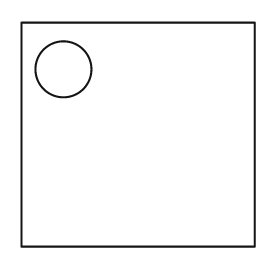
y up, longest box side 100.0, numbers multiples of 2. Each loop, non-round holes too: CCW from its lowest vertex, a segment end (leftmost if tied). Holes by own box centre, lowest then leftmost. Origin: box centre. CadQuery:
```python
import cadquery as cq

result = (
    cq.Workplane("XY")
    .moveTo(-50.0, -48.0)
    .lineTo(50.0, -48.0)
    .lineTo(50.0, 48.0)
    .lineTo(-50.0, 48.0)
    .close()
    .moveTo(-32.0, 28.0)
    .circle(12.0)
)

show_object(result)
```